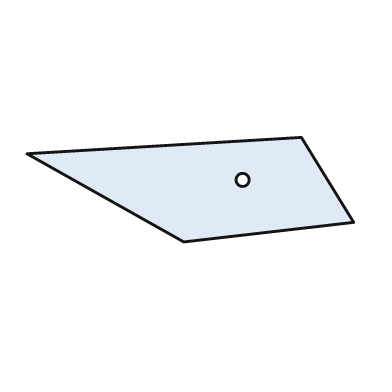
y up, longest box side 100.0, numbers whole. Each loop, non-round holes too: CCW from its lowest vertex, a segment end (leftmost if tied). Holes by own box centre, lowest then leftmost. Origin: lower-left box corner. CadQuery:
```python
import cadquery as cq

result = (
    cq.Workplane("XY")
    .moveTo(48.0, 0.0)
    .lineTo(100.0, 6.0)
    .lineTo(84.0, 32.0)
    .lineTo(0.0, 27.0)
    .close()
    .moveTo(66.0, 19.0)
    .circle(2.0)
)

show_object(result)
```